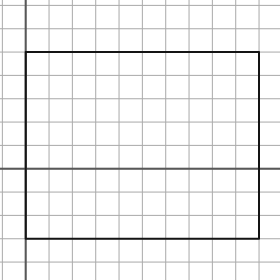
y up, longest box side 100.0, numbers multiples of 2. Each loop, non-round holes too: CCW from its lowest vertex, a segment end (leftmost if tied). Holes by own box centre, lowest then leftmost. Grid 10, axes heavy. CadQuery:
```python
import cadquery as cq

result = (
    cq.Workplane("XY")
    .moveTo(0.0, -30.0)
    .lineTo(100.0, -30.0)
    .lineTo(100.0, 50.0)
    .lineTo(0.0, 50.0)
    .close()
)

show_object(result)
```